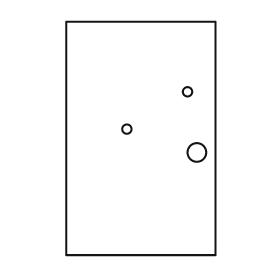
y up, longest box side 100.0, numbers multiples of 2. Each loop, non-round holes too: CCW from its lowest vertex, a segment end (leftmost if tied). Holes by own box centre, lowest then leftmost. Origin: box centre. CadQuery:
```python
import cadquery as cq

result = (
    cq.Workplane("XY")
    .moveTo(-32.0, -50.0)
    .lineTo(32.0, -50.0)
    .lineTo(32.0, 50.0)
    .lineTo(-32.0, 50.0)
    .close()
    .moveTo(24.0, -6.0)
    .circle(4.0)
    .moveTo(-6.0, 4.0)
    .circle(2.0)
    .moveTo(20.0, 20.0)
    .circle(2.0)
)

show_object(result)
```